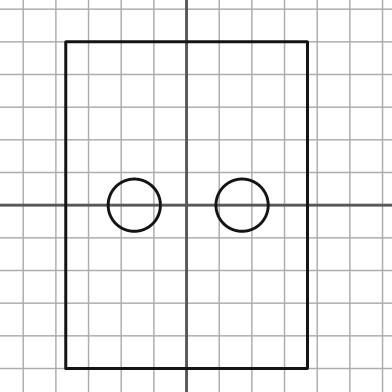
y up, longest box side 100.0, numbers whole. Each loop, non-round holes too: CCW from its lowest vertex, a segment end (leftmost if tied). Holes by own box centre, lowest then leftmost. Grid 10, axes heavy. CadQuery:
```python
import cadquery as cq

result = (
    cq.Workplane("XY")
    .moveTo(-37.0, -50.0)
    .lineTo(37.0, -50.0)
    .lineTo(37.0, 50.0)
    .lineTo(-37.0, 50.0)
    .close()
    .moveTo(-16.0, 0.0)
    .circle(8.0)
    .moveTo(17.0, 0.0)
    .circle(8.0)
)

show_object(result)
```